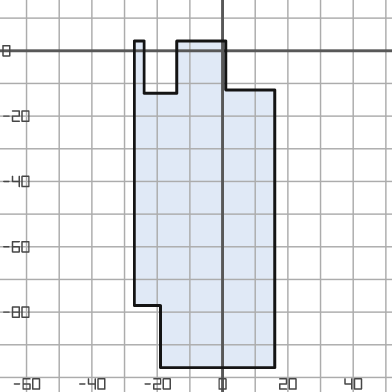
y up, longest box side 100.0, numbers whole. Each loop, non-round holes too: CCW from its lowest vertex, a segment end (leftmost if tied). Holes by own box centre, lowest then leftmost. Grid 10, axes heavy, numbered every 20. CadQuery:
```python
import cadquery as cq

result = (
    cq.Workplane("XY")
    .moveTo(-19.0, -97.0)
    .lineTo(16.0, -97.0)
    .lineTo(16.0, -12.0)
    .lineTo(1.0, -12.0)
    .lineTo(1.0, 3.0)
    .lineTo(-14.0, 3.0)
    .lineTo(-14.0, -13.0)
    .lineTo(-24.0, -13.0)
    .lineTo(-24.0, 3.0)
    .lineTo(-27.0, 3.0)
    .lineTo(-27.0, -78.0)
    .lineTo(-19.0, -78.0)
    .close()
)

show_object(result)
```